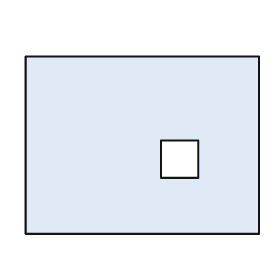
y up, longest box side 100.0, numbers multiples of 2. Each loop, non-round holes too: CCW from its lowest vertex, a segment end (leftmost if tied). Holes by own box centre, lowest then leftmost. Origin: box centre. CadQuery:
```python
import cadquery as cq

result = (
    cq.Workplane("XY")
    .moveTo(-50.0, -38.0)
    .lineTo(50.0, -38.0)
    .lineTo(50.0, 38.0)
    .lineTo(-50.0, 38.0)
    .close()
    .moveTo(8.0, -14.0)
    .lineTo(24.0, -14.0)
    .lineTo(24.0, 2.0)
    .lineTo(8.0, 2.0)
    .close()
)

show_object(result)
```